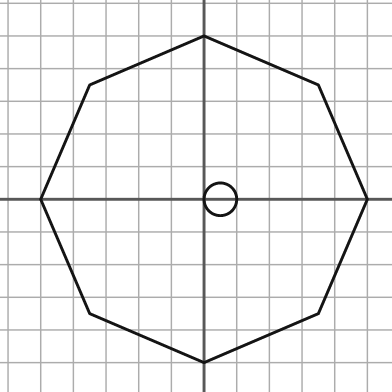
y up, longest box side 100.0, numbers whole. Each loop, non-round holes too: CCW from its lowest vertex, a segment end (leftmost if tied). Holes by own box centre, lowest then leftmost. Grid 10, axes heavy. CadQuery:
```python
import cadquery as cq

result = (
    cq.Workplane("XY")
    .moveTo(0.0, -50.0)
    .lineTo(35.0, -35.0)
    .lineTo(50.0, 0.0)
    .lineTo(35.0, 35.0)
    .lineTo(0.0, 50.0)
    .lineTo(-35.0, 35.0)
    .lineTo(-50.0, 0.0)
    .lineTo(-35.0, -35.0)
    .close()
    .moveTo(5.0, 0.0)
    .circle(5.0)
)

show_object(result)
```